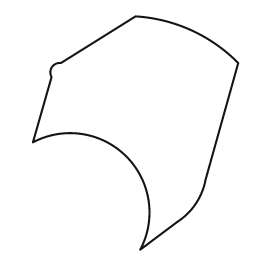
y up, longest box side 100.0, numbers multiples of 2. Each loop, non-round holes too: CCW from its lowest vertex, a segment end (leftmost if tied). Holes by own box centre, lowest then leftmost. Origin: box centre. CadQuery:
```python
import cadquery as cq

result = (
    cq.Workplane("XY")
    .moveTo(2.0, -50.0)
    .lineTo(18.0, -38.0)
    .threePointArc((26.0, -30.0), (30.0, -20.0))
    .lineTo(44.0, 30.0)
    .threePointArc((24.0, 44.0), (0.0, 50.0))
    .lineTo(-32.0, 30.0)
    .threePointArc((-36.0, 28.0), (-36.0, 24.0))
    .lineTo(-44.0, -4.0)
    .threePointArc((-4.0, -10.0), (2.0, -50.0))
    .close()
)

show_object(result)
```